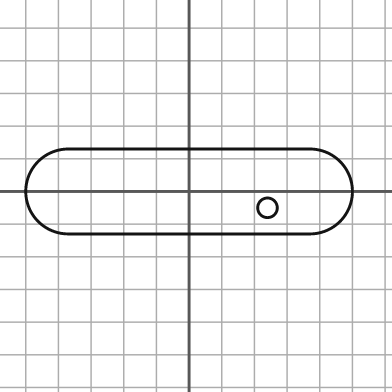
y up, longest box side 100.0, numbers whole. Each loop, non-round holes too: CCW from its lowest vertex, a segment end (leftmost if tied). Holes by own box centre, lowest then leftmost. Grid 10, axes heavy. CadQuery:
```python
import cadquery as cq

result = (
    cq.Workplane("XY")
    .moveTo(-37.0, -13.0)
    .lineTo(37.0, -13.0)
    .threePointArc((50.0, 0.0), (37.0, 13.0))
    .lineTo(-37.0, 13.0)
    .threePointArc((-50.0, 0.0), (-37.0, -13.0))
    .close()
    .moveTo(24.0, -5.0)
    .circle(3.0)
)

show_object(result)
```